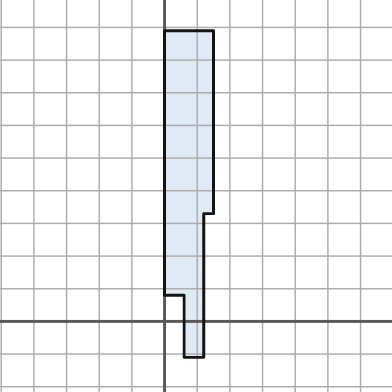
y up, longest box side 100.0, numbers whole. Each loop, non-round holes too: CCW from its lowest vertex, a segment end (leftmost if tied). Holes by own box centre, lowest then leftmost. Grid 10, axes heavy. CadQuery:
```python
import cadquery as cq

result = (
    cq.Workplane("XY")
    .moveTo(6.0, -11.0)
    .lineTo(12.0, -11.0)
    .lineTo(12.0, 33.0)
    .lineTo(15.0, 33.0)
    .lineTo(15.0, 89.0)
    .lineTo(0.0, 89.0)
    .lineTo(0.0, 8.0)
    .lineTo(6.0, 8.0)
    .close()
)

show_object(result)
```